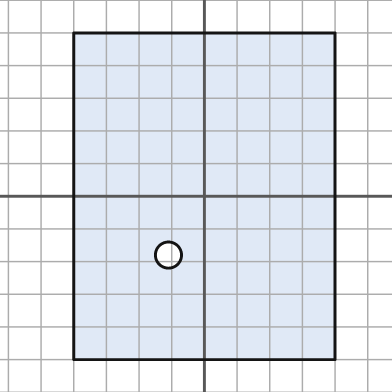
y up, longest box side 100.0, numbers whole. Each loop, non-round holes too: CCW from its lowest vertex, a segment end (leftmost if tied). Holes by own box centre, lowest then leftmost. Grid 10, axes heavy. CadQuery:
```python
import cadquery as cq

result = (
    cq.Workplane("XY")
    .moveTo(-40.0, -50.0)
    .lineTo(40.0, -50.0)
    .lineTo(40.0, 50.0)
    .lineTo(-40.0, 50.0)
    .close()
    .moveTo(-11.0, -18.0)
    .circle(4.0)
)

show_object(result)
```